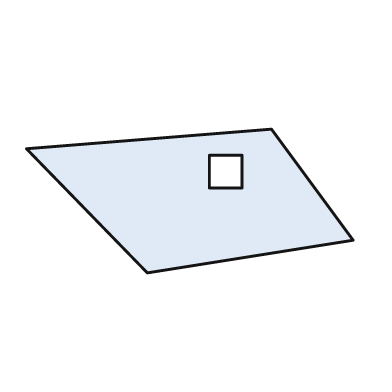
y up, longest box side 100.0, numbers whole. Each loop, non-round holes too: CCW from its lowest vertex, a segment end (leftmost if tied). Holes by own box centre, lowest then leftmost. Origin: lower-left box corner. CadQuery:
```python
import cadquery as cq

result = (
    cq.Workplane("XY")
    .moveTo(37.0, 0.0)
    .lineTo(100.0, 10.0)
    .lineTo(75.0, 44.0)
    .lineTo(0.0, 38.0)
    .close()
    .moveTo(56.0, 26.0)
    .lineTo(66.0, 26.0)
    .lineTo(66.0, 36.0)
    .lineTo(56.0, 36.0)
    .close()
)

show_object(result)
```